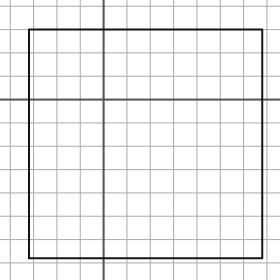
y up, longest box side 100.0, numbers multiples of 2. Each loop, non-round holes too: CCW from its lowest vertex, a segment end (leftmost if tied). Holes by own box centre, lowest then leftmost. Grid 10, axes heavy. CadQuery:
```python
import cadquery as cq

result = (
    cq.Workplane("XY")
    .moveTo(-32.0, -68.0)
    .lineTo(68.0, -68.0)
    .lineTo(68.0, 30.0)
    .lineTo(-32.0, 30.0)
    .close()
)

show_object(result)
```